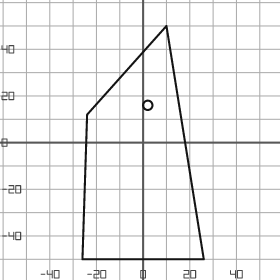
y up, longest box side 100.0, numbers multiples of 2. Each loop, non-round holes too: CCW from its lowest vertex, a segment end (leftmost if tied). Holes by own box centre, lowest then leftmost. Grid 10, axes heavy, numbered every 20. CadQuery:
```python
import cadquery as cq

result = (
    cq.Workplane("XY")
    .moveTo(-26.0, -50.0)
    .lineTo(26.0, -50.0)
    .lineTo(10.0, 50.0)
    .lineTo(-24.0, 12.0)
    .close()
    .moveTo(2.0, 16.0)
    .circle(2.0)
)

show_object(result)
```